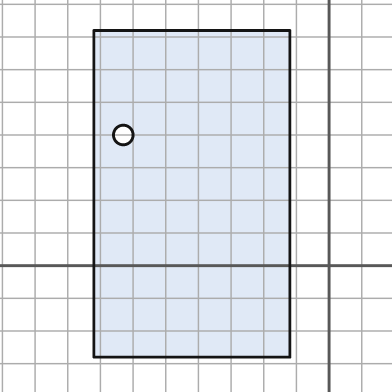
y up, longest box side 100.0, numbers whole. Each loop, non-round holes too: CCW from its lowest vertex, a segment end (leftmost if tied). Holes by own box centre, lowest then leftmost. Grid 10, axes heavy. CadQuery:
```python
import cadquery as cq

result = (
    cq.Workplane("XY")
    .moveTo(-72.0, -28.0)
    .lineTo(-12.0, -28.0)
    .lineTo(-12.0, 72.0)
    .lineTo(-72.0, 72.0)
    .close()
    .moveTo(-63.0, 40.0)
    .circle(3.0)
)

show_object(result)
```